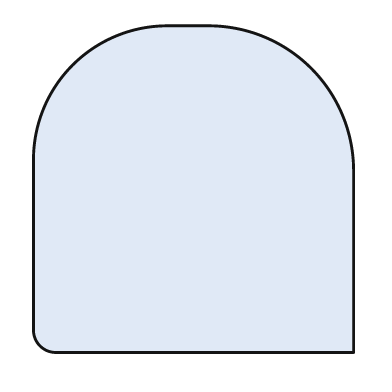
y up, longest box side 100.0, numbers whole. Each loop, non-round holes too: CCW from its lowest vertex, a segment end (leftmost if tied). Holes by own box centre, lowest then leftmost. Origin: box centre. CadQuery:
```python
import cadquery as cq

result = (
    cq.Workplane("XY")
    .moveTo(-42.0, -50.0)
    .lineTo(49.0, -50.0)
    .lineTo(49.0, 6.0)
    .threePointArc((36.0, 37.0), (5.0, 50.0))
    .lineTo(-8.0, 50.0)
    .threePointArc((-37.0, 38.0), (-49.0, 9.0))
    .lineTo(-49.0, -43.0)
    .threePointArc((-47.0, -48.0), (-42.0, -50.0))
    .close()
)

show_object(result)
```